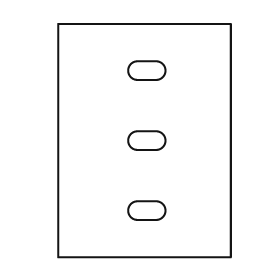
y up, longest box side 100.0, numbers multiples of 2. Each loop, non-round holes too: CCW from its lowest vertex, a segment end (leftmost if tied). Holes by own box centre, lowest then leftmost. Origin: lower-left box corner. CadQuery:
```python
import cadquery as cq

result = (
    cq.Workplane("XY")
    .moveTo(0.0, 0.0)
    .lineTo(74.0, 0.0)
    .lineTo(74.0, 100.0)
    .lineTo(0.0, 100.0)
    .close()
    .moveTo(34.0, 16.0)
    .lineTo(42.0, 16.0)
    .threePointArc((46.0, 20.0), (42.0, 24.0))
    .lineTo(34.0, 24.0)
    .threePointArc((30.0, 20.0), (34.0, 16.0))
    .close()
    .moveTo(34.0, 46.0)
    .lineTo(42.0, 46.0)
    .threePointArc((46.0, 50.0), (42.0, 54.0))
    .lineTo(34.0, 54.0)
    .threePointArc((30.0, 50.0), (34.0, 46.0))
    .close()
    .moveTo(34.0, 76.0)
    .lineTo(42.0, 76.0)
    .threePointArc((46.0, 80.0), (42.0, 84.0))
    .lineTo(34.0, 84.0)
    .threePointArc((30.0, 80.0), (34.0, 76.0))
    .close()
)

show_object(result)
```